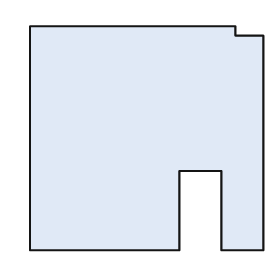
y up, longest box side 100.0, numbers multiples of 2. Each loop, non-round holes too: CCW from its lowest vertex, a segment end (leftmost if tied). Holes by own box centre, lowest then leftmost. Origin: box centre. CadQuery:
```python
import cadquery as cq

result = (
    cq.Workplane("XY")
    .moveTo(-50.0, -48.0)
    .lineTo(14.0, -48.0)
    .lineTo(14.0, -14.0)
    .lineTo(32.0, -14.0)
    .lineTo(32.0, -48.0)
    .lineTo(50.0, -48.0)
    .lineTo(50.0, 44.0)
    .lineTo(38.0, 44.0)
    .lineTo(38.0, 48.0)
    .lineTo(-50.0, 48.0)
    .close()
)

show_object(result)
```